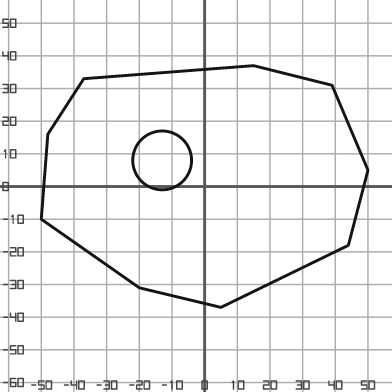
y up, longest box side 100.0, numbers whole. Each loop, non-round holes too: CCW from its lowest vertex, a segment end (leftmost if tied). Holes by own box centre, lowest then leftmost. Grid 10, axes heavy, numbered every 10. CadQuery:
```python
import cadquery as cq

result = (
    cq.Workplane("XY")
    .moveTo(5.0, -37.0)
    .lineTo(44.0, -18.0)
    .lineTo(50.0, 5.0)
    .lineTo(39.0, 31.0)
    .lineTo(15.0, 37.0)
    .lineTo(-37.0, 33.0)
    .lineTo(-48.0, 16.0)
    .lineTo(-50.0, -10.0)
    .lineTo(-20.0, -31.0)
    .close()
    .moveTo(-13.0, 8.0)
    .circle(9.0)
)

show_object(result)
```